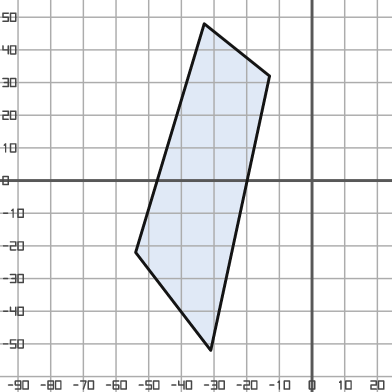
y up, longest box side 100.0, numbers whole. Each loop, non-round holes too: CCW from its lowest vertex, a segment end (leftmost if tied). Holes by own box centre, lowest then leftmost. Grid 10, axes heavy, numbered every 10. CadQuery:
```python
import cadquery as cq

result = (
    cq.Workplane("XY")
    .moveTo(-31.0, -52.0)
    .lineTo(-13.0, 32.0)
    .lineTo(-33.0, 48.0)
    .lineTo(-54.0, -22.0)
    .close()
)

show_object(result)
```